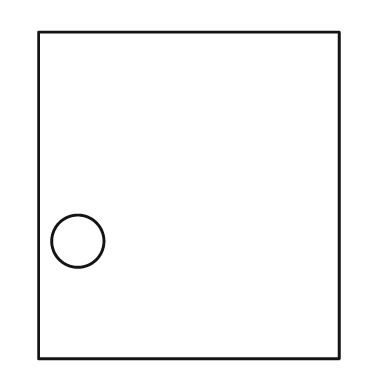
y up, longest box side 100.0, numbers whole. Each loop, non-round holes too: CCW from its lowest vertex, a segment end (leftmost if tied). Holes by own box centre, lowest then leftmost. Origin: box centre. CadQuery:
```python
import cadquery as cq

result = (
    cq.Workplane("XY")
    .moveTo(-46.0, -50.0)
    .lineTo(46.0, -50.0)
    .lineTo(46.0, 50.0)
    .lineTo(-46.0, 50.0)
    .close()
    .moveTo(-34.0, -14.0)
    .circle(8.0)
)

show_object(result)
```